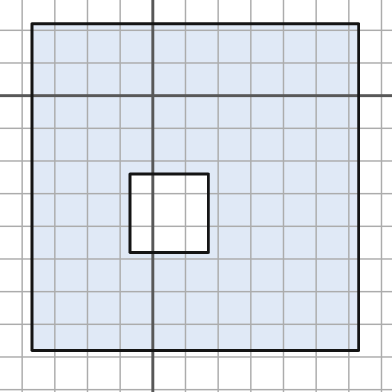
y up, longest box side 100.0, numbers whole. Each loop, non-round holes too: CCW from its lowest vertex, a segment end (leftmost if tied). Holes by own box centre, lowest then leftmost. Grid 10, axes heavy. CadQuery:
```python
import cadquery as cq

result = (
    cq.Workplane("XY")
    .moveTo(-37.0, -78.0)
    .lineTo(63.0, -78.0)
    .lineTo(63.0, 22.0)
    .lineTo(-37.0, 22.0)
    .close()
    .moveTo(-7.0, -48.0)
    .lineTo(17.0, -48.0)
    .lineTo(17.0, -24.0)
    .lineTo(-7.0, -24.0)
    .close()
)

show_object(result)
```